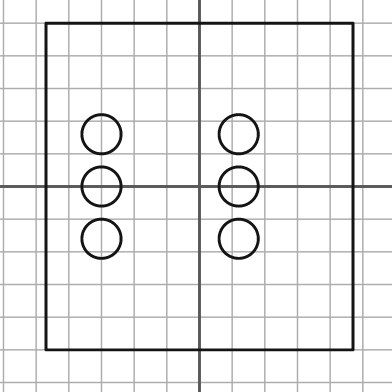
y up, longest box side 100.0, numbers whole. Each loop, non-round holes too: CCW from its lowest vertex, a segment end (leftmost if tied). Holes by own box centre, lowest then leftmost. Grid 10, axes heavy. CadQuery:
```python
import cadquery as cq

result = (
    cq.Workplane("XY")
    .moveTo(-47.0, -50.0)
    .lineTo(47.0, -50.0)
    .lineTo(47.0, 50.0)
    .lineTo(-47.0, 50.0)
    .close()
    .moveTo(-30.0, -16.0)
    .circle(6.0)
    .moveTo(12.0, -16.0)
    .circle(6.0)
    .moveTo(-30.0, 0.0)
    .circle(6.0)
    .moveTo(12.0, 0.0)
    .circle(6.0)
    .moveTo(-30.0, 16.0)
    .circle(6.0)
    .moveTo(12.0, 16.0)
    .circle(6.0)
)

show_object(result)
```